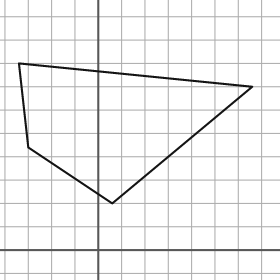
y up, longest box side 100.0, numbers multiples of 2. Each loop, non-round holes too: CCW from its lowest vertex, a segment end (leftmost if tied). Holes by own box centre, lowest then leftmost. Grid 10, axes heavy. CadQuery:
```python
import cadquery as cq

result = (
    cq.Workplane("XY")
    .moveTo(6.0, 20.0)
    .lineTo(66.0, 70.0)
    .lineTo(-34.0, 80.0)
    .lineTo(-30.0, 44.0)
    .close()
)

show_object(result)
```